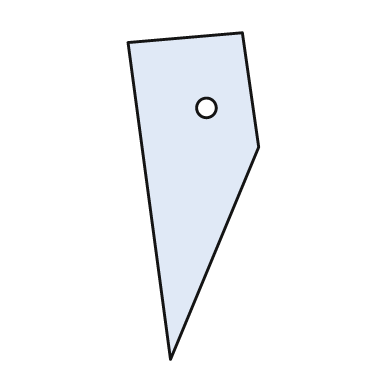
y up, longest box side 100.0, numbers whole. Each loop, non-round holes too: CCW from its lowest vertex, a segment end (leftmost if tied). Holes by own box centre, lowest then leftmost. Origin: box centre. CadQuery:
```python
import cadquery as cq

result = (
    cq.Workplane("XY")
    .moveTo(-7.0, -50.0)
    .lineTo(20.0, 15.0)
    .lineTo(15.0, 50.0)
    .lineTo(-20.0, 47.0)
    .close()
    .moveTo(4.0, 27.0)
    .circle(3.0)
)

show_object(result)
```